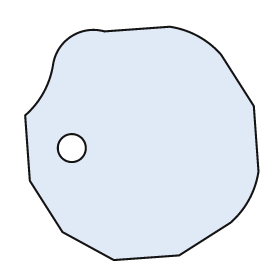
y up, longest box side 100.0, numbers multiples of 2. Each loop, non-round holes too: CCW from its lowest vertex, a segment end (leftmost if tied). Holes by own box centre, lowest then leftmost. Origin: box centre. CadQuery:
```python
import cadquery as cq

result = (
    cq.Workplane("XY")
    .moveTo(-12.0, -50.0)
    .lineTo(16.0, -48.0)
    .lineTo(38.0, -34.0)
    .threePointArc((46.0, -24.0), (50.0, -12.0))
    .lineTo(48.0, 16.0)
    .lineTo(34.0, 38.0)
    .threePointArc((24.0, 46.0), (12.0, 50.0))
    .lineTo(-16.0, 48.0)
    .threePointArc((-30.0, 46.0), (-38.0, 34.0))
    .threePointArc((-42.0, 22.0), (-50.0, 12.0))
    .lineTo(-48.0, -16.0)
    .lineTo(-34.0, -38.0)
    .close()
    .moveTo(-30.0, -2.0)
    .circle(6.0)
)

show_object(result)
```